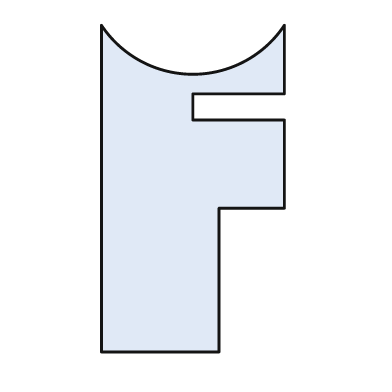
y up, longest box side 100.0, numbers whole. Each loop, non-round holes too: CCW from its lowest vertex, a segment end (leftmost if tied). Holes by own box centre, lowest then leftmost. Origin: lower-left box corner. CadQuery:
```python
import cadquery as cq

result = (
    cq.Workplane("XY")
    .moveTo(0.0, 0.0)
    .lineTo(36.0, 0.0)
    .lineTo(36.0, 44.0)
    .lineTo(56.0, 44.0)
    .lineTo(56.0, 71.0)
    .lineTo(28.0, 71.0)
    .lineTo(28.0, 79.0)
    .lineTo(56.0, 79.0)
    .lineTo(56.0, 100.0)
    .threePointArc((28.0, 85.0), (0.0, 100.0))
    .close()
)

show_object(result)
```